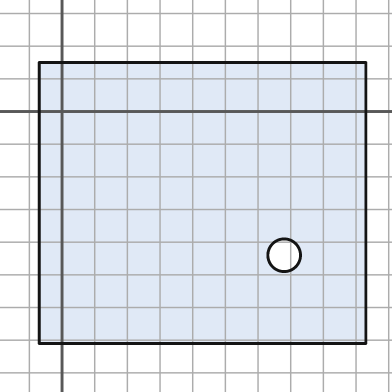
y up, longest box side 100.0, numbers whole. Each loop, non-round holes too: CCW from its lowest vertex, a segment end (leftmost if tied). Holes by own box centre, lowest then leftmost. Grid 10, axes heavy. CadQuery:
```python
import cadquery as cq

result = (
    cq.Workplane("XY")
    .moveTo(-7.0, -71.0)
    .lineTo(93.0, -71.0)
    .lineTo(93.0, 15.0)
    .lineTo(-7.0, 15.0)
    .close()
    .moveTo(68.0, -44.0)
    .circle(5.0)
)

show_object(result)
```